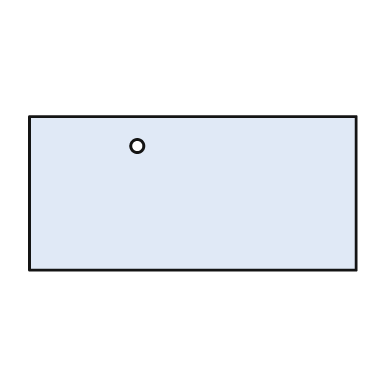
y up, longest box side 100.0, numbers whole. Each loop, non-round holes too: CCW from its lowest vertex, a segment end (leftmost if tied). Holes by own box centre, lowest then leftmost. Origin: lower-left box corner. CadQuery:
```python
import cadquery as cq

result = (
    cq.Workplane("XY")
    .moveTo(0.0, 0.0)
    .lineTo(100.0, 0.0)
    .lineTo(100.0, 47.0)
    .lineTo(0.0, 47.0)
    .close()
    .moveTo(33.0, 38.0)
    .circle(2.0)
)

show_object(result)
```